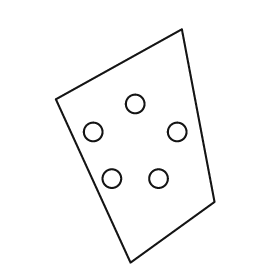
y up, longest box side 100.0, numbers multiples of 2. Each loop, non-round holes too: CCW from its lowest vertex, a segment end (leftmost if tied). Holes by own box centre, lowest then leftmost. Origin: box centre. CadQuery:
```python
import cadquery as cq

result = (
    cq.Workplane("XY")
    .moveTo(-2.0, -50.0)
    .lineTo(34.0, -24.0)
    .lineTo(20.0, 50.0)
    .lineTo(-34.0, 20.0)
    .close()
    .moveTo(-10.0, -14.0)
    .circle(4.0)
    .moveTo(10.0, -14.0)
    .circle(4.0)
    .moveTo(-18.0, 6.0)
    .circle(4.0)
    .moveTo(18.0, 6.0)
    .circle(4.0)
    .moveTo(0.0, 18.0)
    .circle(4.0)
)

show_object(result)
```